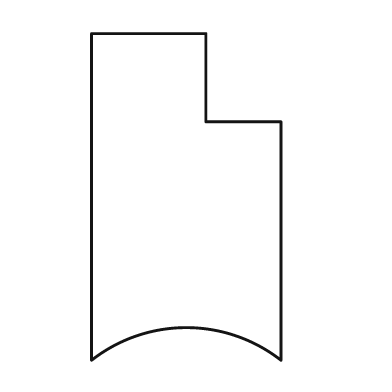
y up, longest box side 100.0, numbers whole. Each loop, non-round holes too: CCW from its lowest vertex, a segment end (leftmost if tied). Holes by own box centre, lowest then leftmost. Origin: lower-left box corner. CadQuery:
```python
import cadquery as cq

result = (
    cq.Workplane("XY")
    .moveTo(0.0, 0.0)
    .threePointArc((29.0, 10.0), (58.0, 0.0))
    .lineTo(58.0, 73.0)
    .lineTo(35.0, 73.0)
    .lineTo(35.0, 100.0)
    .lineTo(0.0, 100.0)
    .close()
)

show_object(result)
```